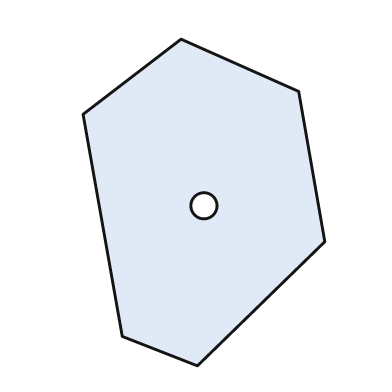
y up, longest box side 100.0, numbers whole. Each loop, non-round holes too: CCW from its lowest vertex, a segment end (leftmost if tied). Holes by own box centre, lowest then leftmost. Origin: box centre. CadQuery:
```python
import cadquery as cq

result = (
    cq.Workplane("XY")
    .moveTo(-2.0, -50.0)
    .lineTo(37.0, -12.0)
    .lineTo(29.0, 34.0)
    .lineTo(-7.0, 50.0)
    .lineTo(-37.0, 27.0)
    .lineTo(-25.0, -41.0)
    .close()
    .moveTo(0.0, -1.0)
    .circle(4.0)
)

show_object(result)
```